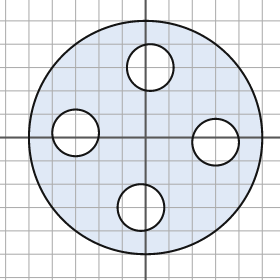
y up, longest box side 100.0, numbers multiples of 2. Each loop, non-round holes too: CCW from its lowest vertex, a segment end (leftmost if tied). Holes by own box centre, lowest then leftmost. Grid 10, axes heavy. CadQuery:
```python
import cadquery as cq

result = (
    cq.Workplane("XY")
    .moveTo(0.0, 0.0)
    .circle(50.0)
    .moveTo(-2.0, -30.0)
    .circle(10.0)
    .moveTo(30.0, -2.0)
    .circle(10.0)
    .moveTo(-30.0, 2.0)
    .circle(10.0)
    .moveTo(2.0, 30.0)
    .circle(10.0)
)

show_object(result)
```